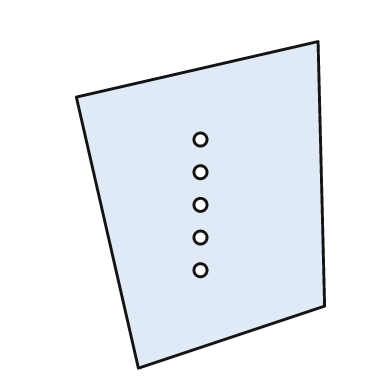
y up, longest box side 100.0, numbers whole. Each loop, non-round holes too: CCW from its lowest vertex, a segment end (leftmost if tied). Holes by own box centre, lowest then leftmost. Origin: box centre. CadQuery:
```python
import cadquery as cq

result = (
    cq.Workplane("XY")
    .moveTo(-19.0, -50.0)
    .lineTo(38.0, -31.0)
    .lineTo(36.0, 50.0)
    .lineTo(-38.0, 33.0)
    .close()
    .moveTo(0.0, -20.0)
    .circle(2.0)
    .moveTo(0.0, -10.0)
    .circle(2.0)
    .moveTo(0.0, 0.0)
    .circle(2.0)
    .moveTo(0.0, 10.0)
    .circle(2.0)
    .moveTo(0.0, 20.0)
    .circle(2.0)
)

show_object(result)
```